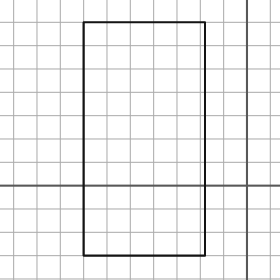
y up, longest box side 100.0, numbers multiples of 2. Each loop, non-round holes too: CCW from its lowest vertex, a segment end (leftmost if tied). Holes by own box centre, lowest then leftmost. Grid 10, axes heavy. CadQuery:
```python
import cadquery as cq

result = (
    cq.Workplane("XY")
    .moveTo(-70.0, -30.0)
    .lineTo(-18.0, -30.0)
    .lineTo(-18.0, 70.0)
    .lineTo(-70.0, 70.0)
    .close()
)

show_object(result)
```